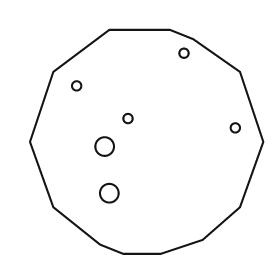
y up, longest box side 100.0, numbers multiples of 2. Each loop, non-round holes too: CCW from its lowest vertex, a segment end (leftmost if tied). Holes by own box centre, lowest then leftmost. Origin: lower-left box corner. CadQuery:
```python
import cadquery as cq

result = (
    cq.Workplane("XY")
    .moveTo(40.0, 0.0)
    .lineTo(56.0, 0.0)
    .lineTo(74.0, 6.0)
    .lineTo(90.0, 20.0)
    .lineTo(100.0, 48.0)
    .lineTo(90.0, 78.0)
    .lineTo(70.0, 92.0)
    .lineTo(60.0, 96.0)
    .lineTo(34.0, 96.0)
    .lineTo(10.0, 78.0)
    .lineTo(0.0, 48.0)
    .lineTo(10.0, 20.0)
    .lineTo(30.0, 4.0)
    .close()
    .moveTo(34.0, 26.0)
    .circle(4.0)
    .moveTo(32.0, 46.0)
    .circle(4.0)
    .moveTo(88.0, 54.0)
    .circle(2.0)
    .moveTo(42.0, 58.0)
    .circle(2.0)
    .moveTo(20.0, 72.0)
    .circle(2.0)
    .moveTo(66.0, 86.0)
    .circle(2.0)
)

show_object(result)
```